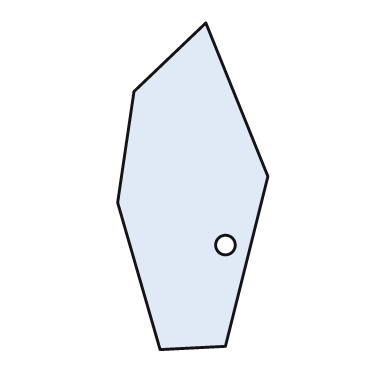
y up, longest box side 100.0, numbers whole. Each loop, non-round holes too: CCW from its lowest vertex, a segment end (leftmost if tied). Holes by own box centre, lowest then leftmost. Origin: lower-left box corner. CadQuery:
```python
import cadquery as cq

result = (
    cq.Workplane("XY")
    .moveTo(13.0, 0.0)
    .lineTo(33.0, 1.0)
    .lineTo(46.0, 53.0)
    .lineTo(27.0, 100.0)
    .lineTo(5.0, 79.0)
    .lineTo(0.0, 45.0)
    .close()
    .moveTo(33.0, 32.0)
    .circle(3.0)
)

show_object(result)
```